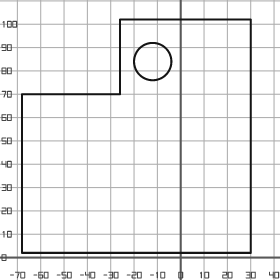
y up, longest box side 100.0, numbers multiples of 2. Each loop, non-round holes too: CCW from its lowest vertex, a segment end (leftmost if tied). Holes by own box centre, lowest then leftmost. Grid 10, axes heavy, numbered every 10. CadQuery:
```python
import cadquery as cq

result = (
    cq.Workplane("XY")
    .moveTo(-68.0, 2.0)
    .lineTo(30.0, 2.0)
    .lineTo(30.0, 102.0)
    .lineTo(-26.0, 102.0)
    .lineTo(-26.0, 70.0)
    .lineTo(-68.0, 70.0)
    .close()
    .moveTo(-12.0, 84.0)
    .circle(8.0)
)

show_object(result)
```